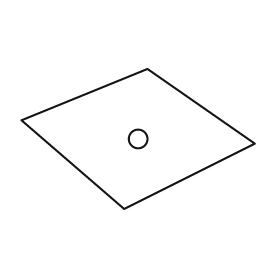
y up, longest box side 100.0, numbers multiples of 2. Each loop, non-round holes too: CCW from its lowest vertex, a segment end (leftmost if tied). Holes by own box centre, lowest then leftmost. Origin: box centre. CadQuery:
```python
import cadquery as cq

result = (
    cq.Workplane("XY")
    .moveTo(-6.0, -30.0)
    .lineTo(50.0, -2.0)
    .lineTo(4.0, 30.0)
    .lineTo(-50.0, 8.0)
    .close()
    .moveTo(0.0, 0.0)
    .circle(4.0)
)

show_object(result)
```